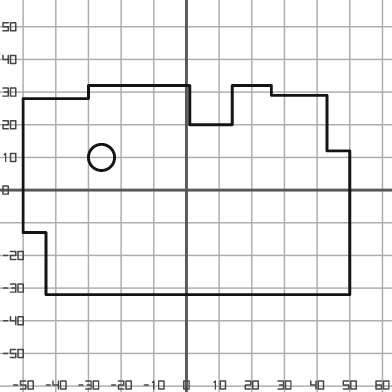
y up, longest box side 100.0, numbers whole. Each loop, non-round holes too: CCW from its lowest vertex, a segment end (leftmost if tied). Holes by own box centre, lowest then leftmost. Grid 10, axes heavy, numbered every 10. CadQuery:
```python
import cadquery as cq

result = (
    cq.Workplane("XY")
    .moveTo(-43.0, -32.0)
    .lineTo(50.0, -32.0)
    .lineTo(50.0, 12.0)
    .lineTo(43.0, 12.0)
    .lineTo(43.0, 29.0)
    .lineTo(26.0, 29.0)
    .lineTo(26.0, 32.0)
    .lineTo(14.0, 32.0)
    .lineTo(14.0, 20.0)
    .lineTo(1.0, 20.0)
    .lineTo(1.0, 32.0)
    .lineTo(-30.0, 32.0)
    .lineTo(-30.0, 28.0)
    .lineTo(-50.0, 28.0)
    .lineTo(-50.0, -13.0)
    .lineTo(-43.0, -13.0)
    .close()
    .moveTo(-26.0, 10.0)
    .circle(4.0)
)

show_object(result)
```